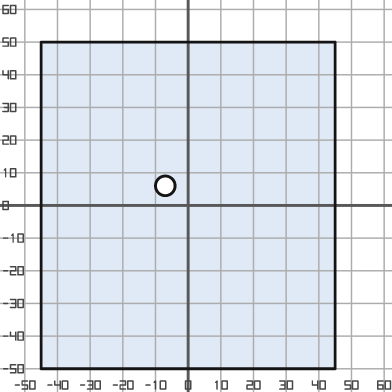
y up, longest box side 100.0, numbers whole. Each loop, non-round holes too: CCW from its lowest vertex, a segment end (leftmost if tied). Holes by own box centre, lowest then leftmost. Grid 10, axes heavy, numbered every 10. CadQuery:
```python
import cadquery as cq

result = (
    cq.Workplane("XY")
    .moveTo(-45.0, -50.0)
    .lineTo(45.0, -50.0)
    .lineTo(45.0, 50.0)
    .lineTo(-45.0, 50.0)
    .close()
    .moveTo(-7.0, 6.0)
    .circle(3.0)
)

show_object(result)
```